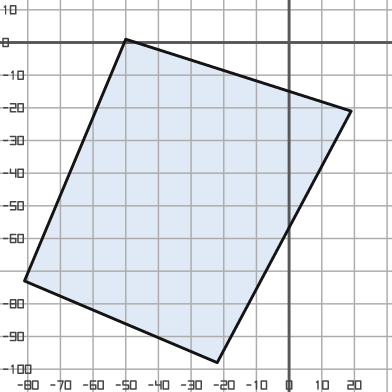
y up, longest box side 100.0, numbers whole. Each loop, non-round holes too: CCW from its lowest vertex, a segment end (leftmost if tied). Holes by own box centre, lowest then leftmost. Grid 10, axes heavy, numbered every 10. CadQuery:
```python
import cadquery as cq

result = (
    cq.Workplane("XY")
    .moveTo(-22.0, -98.0)
    .lineTo(19.0, -21.0)
    .lineTo(-50.0, 1.0)
    .lineTo(-81.0, -73.0)
    .close()
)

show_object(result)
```